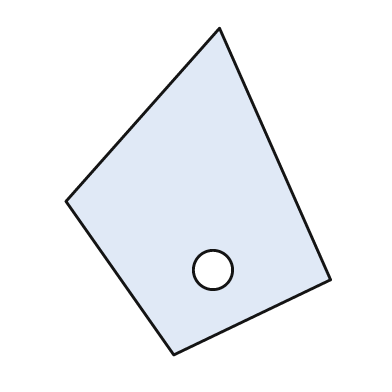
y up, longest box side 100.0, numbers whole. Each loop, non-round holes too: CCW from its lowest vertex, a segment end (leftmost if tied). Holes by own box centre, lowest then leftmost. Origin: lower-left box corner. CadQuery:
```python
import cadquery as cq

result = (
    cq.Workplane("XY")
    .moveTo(33.0, 0.0)
    .lineTo(81.0, 23.0)
    .lineTo(47.0, 100.0)
    .lineTo(0.0, 47.0)
    .close()
    .moveTo(45.0, 26.0)
    .circle(6.0)
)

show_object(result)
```